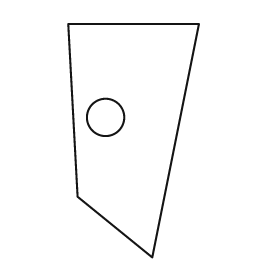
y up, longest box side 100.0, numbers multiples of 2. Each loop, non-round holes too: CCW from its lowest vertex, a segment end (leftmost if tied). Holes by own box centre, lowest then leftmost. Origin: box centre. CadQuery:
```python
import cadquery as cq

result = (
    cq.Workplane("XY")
    .moveTo(8.0, -50.0)
    .lineTo(28.0, 50.0)
    .lineTo(-28.0, 50.0)
    .lineTo(-24.0, -24.0)
    .close()
    .moveTo(-12.0, 10.0)
    .circle(8.0)
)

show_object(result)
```